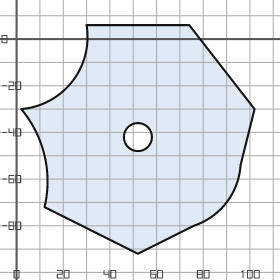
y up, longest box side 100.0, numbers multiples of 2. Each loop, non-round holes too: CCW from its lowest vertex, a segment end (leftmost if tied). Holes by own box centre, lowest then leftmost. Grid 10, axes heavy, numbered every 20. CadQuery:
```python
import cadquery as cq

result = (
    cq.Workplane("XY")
    .moveTo(52.0, -92.0)
    .lineTo(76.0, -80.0)
    .threePointArc((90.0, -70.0), (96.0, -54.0))
    .lineTo(102.0, -30.0)
    .lineTo(74.0, 6.0)
    .lineTo(30.0, 6.0)
    .threePointArc((24.0, -18.0), (2.0, -30.0))
    .threePointArc((12.0, -50.0), (12.0, -72.0))
    .close()
    .moveTo(52.0, -42.0)
    .circle(6.0)
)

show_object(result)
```